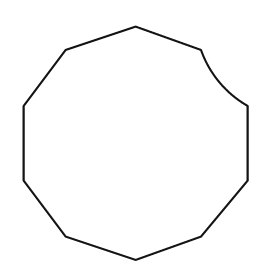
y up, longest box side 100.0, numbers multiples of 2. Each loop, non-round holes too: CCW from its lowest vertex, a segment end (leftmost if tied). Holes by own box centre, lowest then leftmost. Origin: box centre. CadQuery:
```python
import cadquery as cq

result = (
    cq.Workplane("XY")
    .moveTo(0.0, -50.0)
    .lineTo(28.0, -40.0)
    .lineTo(48.0, -16.0)
    .lineTo(48.0, 16.0)
    .threePointArc((36.0, 26.0), (28.0, 40.0))
    .lineTo(0.0, 50.0)
    .lineTo(-30.0, 40.0)
    .lineTo(-48.0, 16.0)
    .lineTo(-48.0, -16.0)
    .lineTo(-30.0, -40.0)
    .close()
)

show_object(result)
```